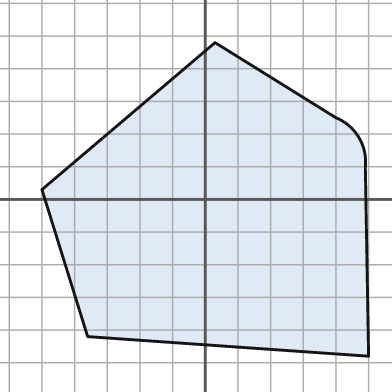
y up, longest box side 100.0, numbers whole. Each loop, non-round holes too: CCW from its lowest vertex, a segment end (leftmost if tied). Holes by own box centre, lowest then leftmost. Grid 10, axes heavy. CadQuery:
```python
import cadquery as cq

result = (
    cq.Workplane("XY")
    .moveTo(50.0, -48.0)
    .lineTo(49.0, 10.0)
    .threePointArc((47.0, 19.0), (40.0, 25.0))
    .lineTo(3.0, 48.0)
    .lineTo(-50.0, 3.0)
    .lineTo(-36.0, -42.0)
    .close()
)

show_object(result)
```